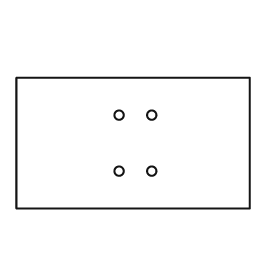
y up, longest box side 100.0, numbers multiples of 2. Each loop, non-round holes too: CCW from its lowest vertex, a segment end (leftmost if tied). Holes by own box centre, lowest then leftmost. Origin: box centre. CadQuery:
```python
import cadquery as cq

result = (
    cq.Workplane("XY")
    .moveTo(-50.0, -28.0)
    .lineTo(50.0, -28.0)
    .lineTo(50.0, 28.0)
    .lineTo(-50.0, 28.0)
    .close()
    .moveTo(-6.0, -12.0)
    .circle(2.0)
    .moveTo(8.0, -12.0)
    .circle(2.0)
    .moveTo(-6.0, 12.0)
    .circle(2.0)
    .moveTo(8.0, 12.0)
    .circle(2.0)
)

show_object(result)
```